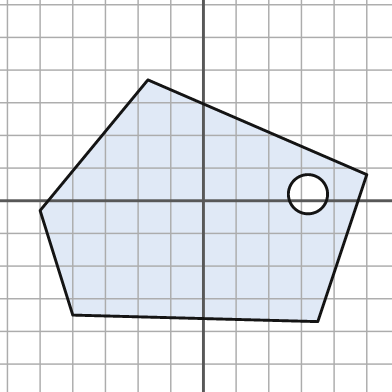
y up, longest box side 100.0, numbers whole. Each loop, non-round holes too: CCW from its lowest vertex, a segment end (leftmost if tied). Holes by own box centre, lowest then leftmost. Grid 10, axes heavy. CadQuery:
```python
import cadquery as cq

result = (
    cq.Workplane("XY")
    .moveTo(35.0, -37.0)
    .lineTo(50.0, 8.0)
    .lineTo(-17.0, 37.0)
    .lineTo(-50.0, -3.0)
    .lineTo(-40.0, -35.0)
    .close()
    .moveTo(32.0, 2.0)
    .circle(6.0)
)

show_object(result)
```